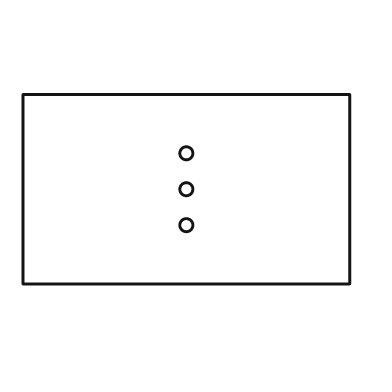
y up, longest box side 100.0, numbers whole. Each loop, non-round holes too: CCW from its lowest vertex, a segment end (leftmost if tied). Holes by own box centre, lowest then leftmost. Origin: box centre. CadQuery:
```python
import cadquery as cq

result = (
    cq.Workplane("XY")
    .moveTo(-50.0, -29.0)
    .lineTo(50.0, -29.0)
    .lineTo(50.0, 29.0)
    .lineTo(-50.0, 29.0)
    .close()
    .moveTo(0.0, -11.0)
    .circle(2.0)
    .moveTo(0.0, 0.0)
    .circle(2.0)
    .moveTo(0.0, 11.0)
    .circle(2.0)
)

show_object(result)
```